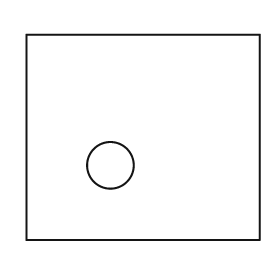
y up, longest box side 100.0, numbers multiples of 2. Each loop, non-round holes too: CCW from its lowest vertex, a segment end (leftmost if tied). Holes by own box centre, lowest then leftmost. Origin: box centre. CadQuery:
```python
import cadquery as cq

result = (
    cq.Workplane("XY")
    .moveTo(-50.0, -44.0)
    .lineTo(50.0, -44.0)
    .lineTo(50.0, 44.0)
    .lineTo(-50.0, 44.0)
    .close()
    .moveTo(-14.0, -12.0)
    .circle(10.0)
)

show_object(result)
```